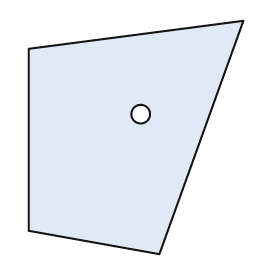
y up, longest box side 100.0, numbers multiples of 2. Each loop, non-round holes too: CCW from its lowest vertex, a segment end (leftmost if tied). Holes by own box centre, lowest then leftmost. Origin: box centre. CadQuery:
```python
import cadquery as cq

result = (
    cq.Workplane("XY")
    .moveTo(10.0, -50.0)
    .lineTo(46.0, 50.0)
    .lineTo(-46.0, 38.0)
    .lineTo(-46.0, -40.0)
    .close()
    .moveTo(2.0, 10.0)
    .circle(4.0)
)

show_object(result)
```